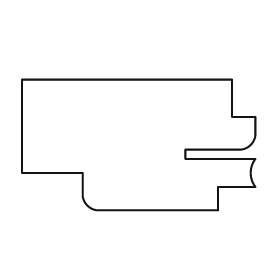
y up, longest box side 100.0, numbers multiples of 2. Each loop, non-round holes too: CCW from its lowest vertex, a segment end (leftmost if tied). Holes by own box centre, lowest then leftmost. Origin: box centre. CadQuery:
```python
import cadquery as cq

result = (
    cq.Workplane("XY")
    .moveTo(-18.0, -28.0)
    .lineTo(34.0, -28.0)
    .lineTo(34.0, -18.0)
    .lineTo(50.0, -18.0)
    .threePointArc((48.0, -12.0), (50.0, -6.0))
    .lineTo(20.0, -6.0)
    .lineTo(20.0, -2.0)
    .lineTo(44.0, -2.0)
    .threePointArc((48.0, 0.0), (50.0, 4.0))
    .lineTo(50.0, 12.0)
    .lineTo(40.0, 12.0)
    .lineTo(40.0, 28.0)
    .lineTo(-50.0, 28.0)
    .lineTo(-50.0, -12.0)
    .lineTo(-24.0, -12.0)
    .lineTo(-24.0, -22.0)
    .threePointArc((-22.0, -26.0), (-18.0, -28.0))
    .close()
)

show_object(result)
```